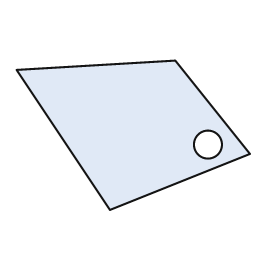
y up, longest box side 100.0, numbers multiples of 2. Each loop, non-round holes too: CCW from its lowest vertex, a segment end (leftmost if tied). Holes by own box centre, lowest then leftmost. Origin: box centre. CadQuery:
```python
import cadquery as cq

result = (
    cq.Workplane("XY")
    .moveTo(-10.0, -32.0)
    .lineTo(50.0, -8.0)
    .lineTo(18.0, 32.0)
    .lineTo(-50.0, 28.0)
    .close()
    .moveTo(32.0, -4.0)
    .circle(6.0)
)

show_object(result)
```